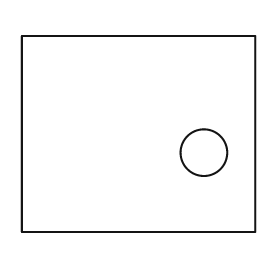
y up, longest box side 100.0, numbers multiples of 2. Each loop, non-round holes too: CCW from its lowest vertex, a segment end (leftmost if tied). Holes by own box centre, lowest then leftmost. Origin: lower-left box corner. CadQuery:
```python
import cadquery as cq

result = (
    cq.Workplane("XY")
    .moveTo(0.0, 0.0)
    .lineTo(100.0, 0.0)
    .lineTo(100.0, 84.0)
    .lineTo(0.0, 84.0)
    .close()
    .moveTo(78.0, 34.0)
    .circle(10.0)
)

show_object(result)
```